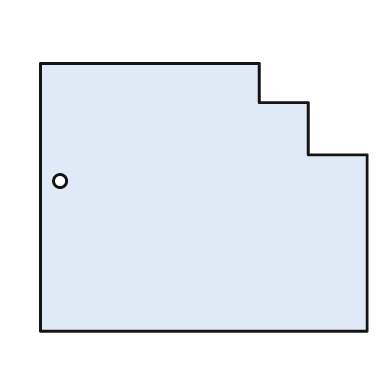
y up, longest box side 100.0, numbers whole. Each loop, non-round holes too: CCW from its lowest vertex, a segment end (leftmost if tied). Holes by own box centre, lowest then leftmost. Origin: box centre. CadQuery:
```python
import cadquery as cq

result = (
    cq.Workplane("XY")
    .moveTo(-50.0, -41.0)
    .lineTo(50.0, -41.0)
    .lineTo(50.0, 13.0)
    .lineTo(32.0, 13.0)
    .lineTo(32.0, 29.0)
    .lineTo(17.0, 29.0)
    .lineTo(17.0, 41.0)
    .lineTo(-50.0, 41.0)
    .close()
    .moveTo(-44.0, 5.0)
    .circle(2.0)
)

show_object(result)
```